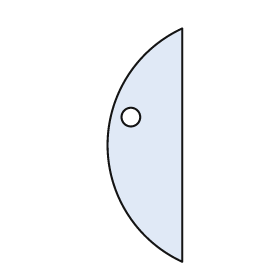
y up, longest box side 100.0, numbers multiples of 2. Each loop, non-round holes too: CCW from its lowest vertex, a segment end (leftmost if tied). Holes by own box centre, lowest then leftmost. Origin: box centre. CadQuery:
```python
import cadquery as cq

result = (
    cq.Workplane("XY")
    .moveTo(16.0, -50.0)
    .lineTo(16.0, 50.0)
    .threePointArc((-16.0, 0.0), (16.0, -50.0))
    .close()
    .moveTo(-6.0, 12.0)
    .circle(4.0)
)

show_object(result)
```